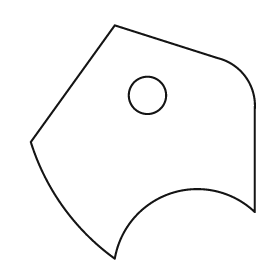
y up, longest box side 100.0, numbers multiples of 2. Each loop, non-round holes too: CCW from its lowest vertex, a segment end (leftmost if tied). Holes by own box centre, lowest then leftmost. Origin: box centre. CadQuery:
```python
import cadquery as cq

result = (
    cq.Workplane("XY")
    .moveTo(-12.0, -50.0)
    .threePointArc((12.0, -22.0), (48.0, -30.0))
    .lineTo(48.0, 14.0)
    .threePointArc((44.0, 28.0), (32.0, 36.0))
    .lineTo(-12.0, 50.0)
    .lineTo(-48.0, 0.0)
    .threePointArc((-34.0, -28.0), (-12.0, -50.0))
    .close()
    .moveTo(2.0, 20.0)
    .circle(8.0)
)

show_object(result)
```